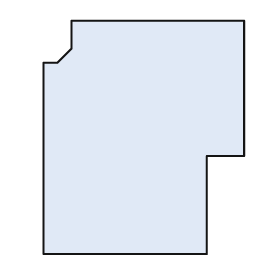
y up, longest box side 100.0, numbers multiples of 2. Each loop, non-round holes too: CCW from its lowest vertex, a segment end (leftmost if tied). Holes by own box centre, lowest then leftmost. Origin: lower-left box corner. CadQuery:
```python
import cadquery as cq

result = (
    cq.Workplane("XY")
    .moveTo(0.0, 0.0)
    .lineTo(70.0, 0.0)
    .lineTo(70.0, 42.0)
    .lineTo(86.0, 42.0)
    .lineTo(86.0, 100.0)
    .lineTo(12.0, 100.0)
    .lineTo(12.0, 88.0)
    .lineTo(6.0, 82.0)
    .lineTo(0.0, 82.0)
    .close()
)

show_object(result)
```